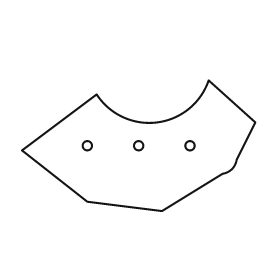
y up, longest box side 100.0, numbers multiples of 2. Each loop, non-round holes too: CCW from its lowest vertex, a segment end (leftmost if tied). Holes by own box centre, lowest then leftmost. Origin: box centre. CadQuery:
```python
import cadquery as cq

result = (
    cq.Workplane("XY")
    .moveTo(10.0, -28.0)
    .lineTo(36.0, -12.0)
    .threePointArc((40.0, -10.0), (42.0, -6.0))
    .lineTo(50.0, 10.0)
    .lineTo(30.0, 28.0)
    .threePointArc((8.0, 10.0), (-18.0, 22.0))
    .lineTo(-50.0, -2.0)
    .lineTo(-22.0, -24.0)
    .close()
    .moveTo(-22.0, 0.0)
    .circle(2.0)
    .moveTo(0.0, 0.0)
    .circle(2.0)
    .moveTo(22.0, 0.0)
    .circle(2.0)
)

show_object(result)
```